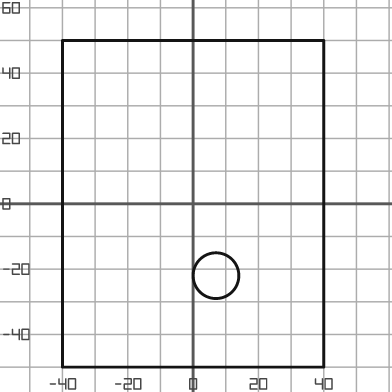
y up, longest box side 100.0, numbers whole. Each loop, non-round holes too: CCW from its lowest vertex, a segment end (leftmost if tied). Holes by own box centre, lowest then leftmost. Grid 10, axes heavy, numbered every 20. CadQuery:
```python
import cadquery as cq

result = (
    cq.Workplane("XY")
    .moveTo(-40.0, -50.0)
    .lineTo(40.0, -50.0)
    .lineTo(40.0, 50.0)
    .lineTo(-40.0, 50.0)
    .close()
    .moveTo(7.0, -22.0)
    .circle(7.0)
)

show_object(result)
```